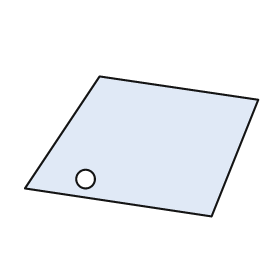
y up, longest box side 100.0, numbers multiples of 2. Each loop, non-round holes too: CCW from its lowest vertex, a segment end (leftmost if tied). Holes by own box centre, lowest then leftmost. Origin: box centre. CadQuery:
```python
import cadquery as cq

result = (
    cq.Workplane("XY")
    .moveTo(30.0, -30.0)
    .lineTo(50.0, 20.0)
    .lineTo(-18.0, 30.0)
    .lineTo(-50.0, -18.0)
    .close()
    .moveTo(-24.0, -14.0)
    .circle(4.0)
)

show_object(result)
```